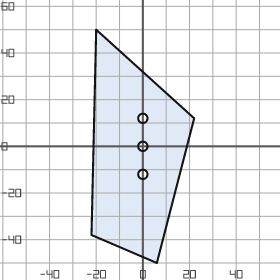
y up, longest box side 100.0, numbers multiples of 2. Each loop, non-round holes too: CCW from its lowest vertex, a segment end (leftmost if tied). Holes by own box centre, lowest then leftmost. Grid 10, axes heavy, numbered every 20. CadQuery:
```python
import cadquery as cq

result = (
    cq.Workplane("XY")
    .moveTo(6.0, -50.0)
    .lineTo(22.0, 12.0)
    .lineTo(-20.0, 50.0)
    .lineTo(-22.0, -38.0)
    .close()
    .moveTo(0.0, -12.0)
    .circle(2.0)
    .moveTo(0.0, 0.0)
    .circle(2.0)
    .moveTo(0.0, 12.0)
    .circle(2.0)
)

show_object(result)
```